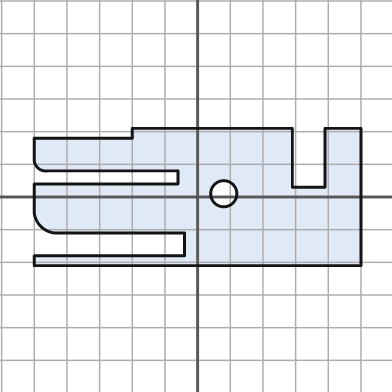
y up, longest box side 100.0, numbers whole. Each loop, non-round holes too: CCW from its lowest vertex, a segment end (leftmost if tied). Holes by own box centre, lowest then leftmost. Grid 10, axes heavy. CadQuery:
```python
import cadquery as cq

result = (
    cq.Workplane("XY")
    .moveTo(-50.0, -21.0)
    .lineTo(50.0, -21.0)
    .lineTo(50.0, 21.0)
    .lineTo(39.0, 21.0)
    .lineTo(39.0, 3.0)
    .lineTo(29.0, 3.0)
    .lineTo(29.0, 21.0)
    .lineTo(-20.0, 21.0)
    .lineTo(-20.0, 18.0)
    .lineTo(-50.0, 18.0)
    .lineTo(-50.0, 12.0)
    .threePointArc((-49.0, 9.0), (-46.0, 8.0))
    .lineTo(-6.0, 8.0)
    .lineTo(-6.0, 4.0)
    .lineTo(-50.0, 4.0)
    .lineTo(-50.0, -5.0)
    .threePointArc((-48.0, -9.0), (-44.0, -11.0))
    .lineTo(-4.0, -11.0)
    .lineTo(-4.0, -18.0)
    .lineTo(-50.0, -18.0)
    .close()
    .moveTo(8.0, 1.0)
    .circle(4.0)
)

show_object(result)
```